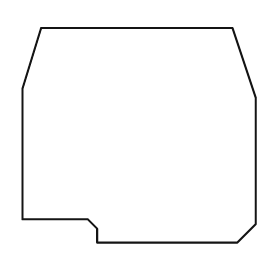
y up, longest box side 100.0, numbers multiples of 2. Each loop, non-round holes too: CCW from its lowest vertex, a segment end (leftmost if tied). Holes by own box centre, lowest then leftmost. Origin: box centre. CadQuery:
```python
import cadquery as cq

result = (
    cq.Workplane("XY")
    .moveTo(-18.0, -46.0)
    .lineTo(42.0, -46.0)
    .lineTo(50.0, -38.0)
    .lineTo(50.0, 16.0)
    .lineTo(40.0, 46.0)
    .lineTo(-42.0, 46.0)
    .lineTo(-50.0, 20.0)
    .lineTo(-50.0, -36.0)
    .lineTo(-22.0, -36.0)
    .lineTo(-18.0, -40.0)
    .close()
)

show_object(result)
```